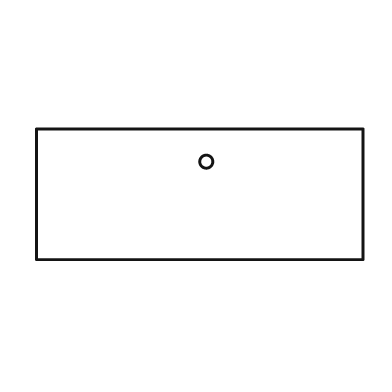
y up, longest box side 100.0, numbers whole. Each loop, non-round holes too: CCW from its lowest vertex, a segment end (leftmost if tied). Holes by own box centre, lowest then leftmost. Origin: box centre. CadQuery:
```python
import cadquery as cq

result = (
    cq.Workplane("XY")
    .moveTo(-50.0, -20.0)
    .lineTo(50.0, -20.0)
    .lineTo(50.0, 20.0)
    .lineTo(-50.0, 20.0)
    .close()
    .moveTo(2.0, 10.0)
    .circle(2.0)
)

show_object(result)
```